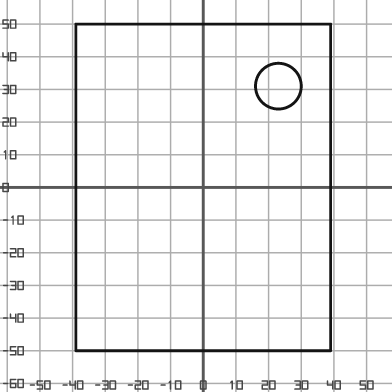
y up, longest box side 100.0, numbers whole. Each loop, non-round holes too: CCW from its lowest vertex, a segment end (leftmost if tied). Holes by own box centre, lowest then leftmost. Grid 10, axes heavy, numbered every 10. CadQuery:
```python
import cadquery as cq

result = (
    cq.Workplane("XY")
    .moveTo(-39.0, -50.0)
    .lineTo(39.0, -50.0)
    .lineTo(39.0, 50.0)
    .lineTo(-39.0, 50.0)
    .close()
    .moveTo(23.0, 31.0)
    .circle(7.0)
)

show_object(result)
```